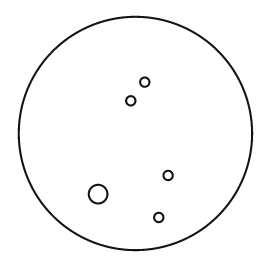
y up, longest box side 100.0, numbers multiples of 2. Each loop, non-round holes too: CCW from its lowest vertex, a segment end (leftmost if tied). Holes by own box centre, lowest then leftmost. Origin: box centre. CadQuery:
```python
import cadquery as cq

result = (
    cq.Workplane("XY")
    .moveTo(0.0, 0.0)
    .circle(50.0)
    .moveTo(10.0, -36.0)
    .circle(2.0)
    .moveTo(-16.0, -26.0)
    .circle(4.0)
    .moveTo(14.0, -18.0)
    .circle(2.0)
    .moveTo(-2.0, 14.0)
    .circle(2.0)
    .moveTo(4.0, 22.0)
    .circle(2.0)
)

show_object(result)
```